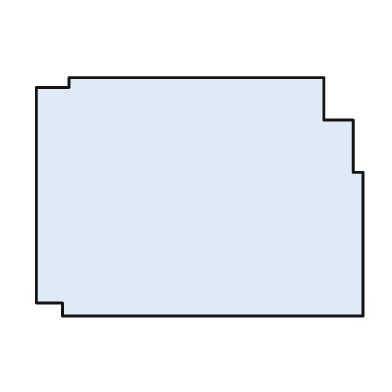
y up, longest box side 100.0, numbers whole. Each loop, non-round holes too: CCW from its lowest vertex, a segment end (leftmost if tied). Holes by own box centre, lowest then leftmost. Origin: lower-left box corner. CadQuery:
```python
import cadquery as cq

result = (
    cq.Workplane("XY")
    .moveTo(8.0, 0.0)
    .lineTo(100.0, 0.0)
    .lineTo(100.0, 44.0)
    .lineTo(97.0, 44.0)
    .lineTo(97.0, 60.0)
    .lineTo(88.0, 60.0)
    .lineTo(88.0, 73.0)
    .lineTo(10.0, 73.0)
    .lineTo(10.0, 70.0)
    .lineTo(0.0, 70.0)
    .lineTo(0.0, 4.0)
    .lineTo(8.0, 4.0)
    .close()
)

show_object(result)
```